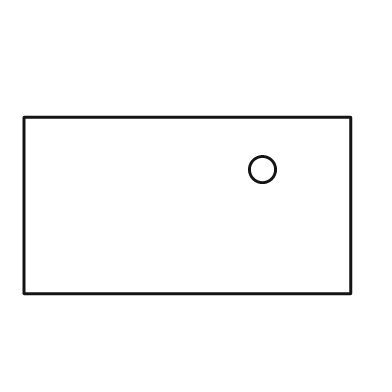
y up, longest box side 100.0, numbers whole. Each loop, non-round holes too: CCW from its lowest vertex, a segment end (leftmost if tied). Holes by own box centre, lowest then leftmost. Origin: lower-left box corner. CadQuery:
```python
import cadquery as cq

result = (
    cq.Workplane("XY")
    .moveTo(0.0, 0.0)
    .lineTo(100.0, 0.0)
    .lineTo(100.0, 54.0)
    .lineTo(0.0, 54.0)
    .close()
    .moveTo(73.0, 38.0)
    .circle(4.0)
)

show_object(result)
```